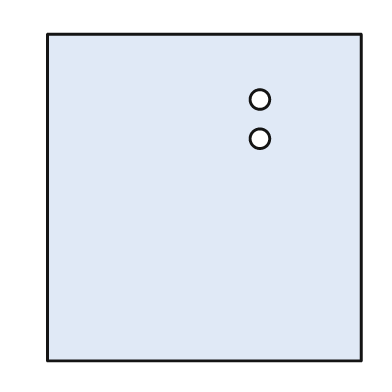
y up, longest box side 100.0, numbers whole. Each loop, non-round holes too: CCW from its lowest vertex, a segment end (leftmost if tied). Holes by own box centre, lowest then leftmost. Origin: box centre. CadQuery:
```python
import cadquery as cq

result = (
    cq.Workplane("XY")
    .moveTo(-48.0, -50.0)
    .lineTo(48.0, -50.0)
    .lineTo(48.0, 50.0)
    .lineTo(-48.0, 50.0)
    .close()
    .moveTo(17.0, 18.0)
    .circle(3.0)
    .moveTo(17.0, 30.0)
    .circle(3.0)
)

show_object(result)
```